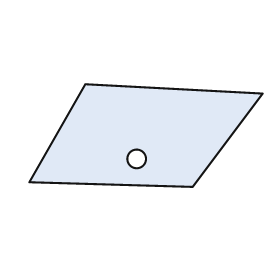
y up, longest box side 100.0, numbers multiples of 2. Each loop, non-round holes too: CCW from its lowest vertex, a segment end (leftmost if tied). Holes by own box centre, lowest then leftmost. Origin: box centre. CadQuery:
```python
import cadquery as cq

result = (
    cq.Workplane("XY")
    .moveTo(20.0, -22.0)
    .lineTo(50.0, 18.0)
    .lineTo(-26.0, 22.0)
    .lineTo(-50.0, -20.0)
    .close()
    .moveTo(-4.0, -10.0)
    .circle(4.0)
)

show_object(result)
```